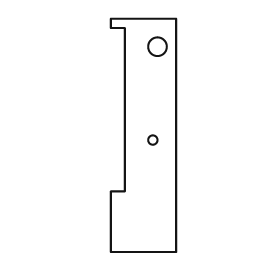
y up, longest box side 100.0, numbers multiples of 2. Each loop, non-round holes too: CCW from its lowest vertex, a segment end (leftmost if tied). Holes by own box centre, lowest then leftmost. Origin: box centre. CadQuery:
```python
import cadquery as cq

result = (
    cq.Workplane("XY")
    .moveTo(-14.0, -50.0)
    .lineTo(14.0, -50.0)
    .lineTo(14.0, 50.0)
    .lineTo(-14.0, 50.0)
    .lineTo(-14.0, 46.0)
    .lineTo(-8.0, 46.0)
    .lineTo(-8.0, -24.0)
    .lineTo(-14.0, -24.0)
    .close()
    .moveTo(4.0, -2.0)
    .circle(2.0)
    .moveTo(6.0, 38.0)
    .circle(4.0)
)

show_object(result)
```